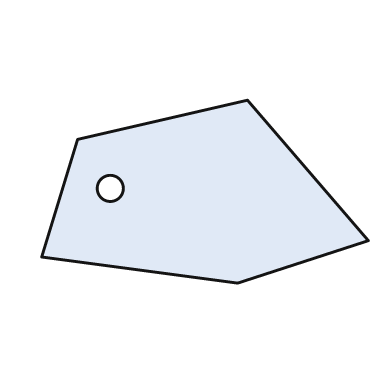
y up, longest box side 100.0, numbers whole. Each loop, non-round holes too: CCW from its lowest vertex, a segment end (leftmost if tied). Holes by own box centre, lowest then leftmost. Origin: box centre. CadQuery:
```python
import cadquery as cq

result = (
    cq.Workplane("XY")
    .moveTo(10.0, -28.0)
    .lineTo(50.0, -15.0)
    .lineTo(13.0, 28.0)
    .lineTo(-39.0, 16.0)
    .lineTo(-50.0, -20.0)
    .close()
    .moveTo(-29.0, 1.0)
    .circle(4.0)
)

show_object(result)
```